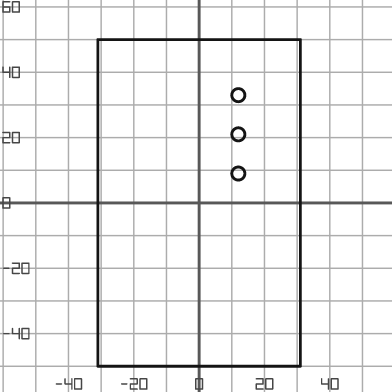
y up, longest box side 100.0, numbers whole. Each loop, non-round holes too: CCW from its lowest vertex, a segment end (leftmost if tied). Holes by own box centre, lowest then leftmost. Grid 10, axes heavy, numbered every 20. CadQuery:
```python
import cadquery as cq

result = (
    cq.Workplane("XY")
    .moveTo(-31.0, -50.0)
    .lineTo(31.0, -50.0)
    .lineTo(31.0, 50.0)
    .lineTo(-31.0, 50.0)
    .close()
    .moveTo(12.0, 9.0)
    .circle(2.0)
    .moveTo(12.0, 21.0)
    .circle(2.0)
    .moveTo(12.0, 33.0)
    .circle(2.0)
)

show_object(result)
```